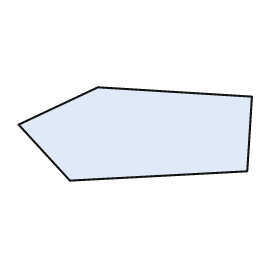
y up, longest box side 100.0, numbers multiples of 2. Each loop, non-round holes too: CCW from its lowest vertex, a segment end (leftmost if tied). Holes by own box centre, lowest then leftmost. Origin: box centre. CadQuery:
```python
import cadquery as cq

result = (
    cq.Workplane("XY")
    .moveTo(-28.0, -20.0)
    .lineTo(48.0, -16.0)
    .lineTo(50.0, 16.0)
    .lineTo(-16.0, 20.0)
    .lineTo(-50.0, 4.0)
    .close()
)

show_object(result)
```